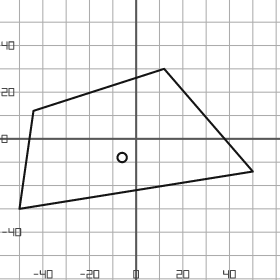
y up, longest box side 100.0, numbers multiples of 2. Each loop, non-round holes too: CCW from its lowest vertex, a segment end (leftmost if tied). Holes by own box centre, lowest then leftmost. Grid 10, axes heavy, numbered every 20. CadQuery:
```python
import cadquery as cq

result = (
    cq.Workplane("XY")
    .moveTo(-50.0, -30.0)
    .lineTo(50.0, -14.0)
    .lineTo(12.0, 30.0)
    .lineTo(-44.0, 12.0)
    .close()
    .moveTo(-6.0, -8.0)
    .circle(2.0)
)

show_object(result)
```